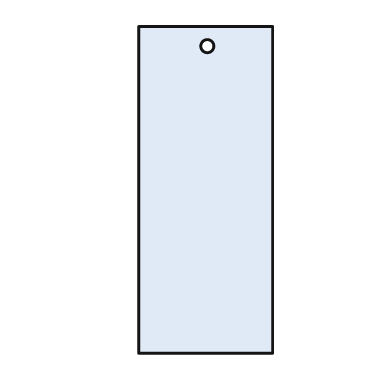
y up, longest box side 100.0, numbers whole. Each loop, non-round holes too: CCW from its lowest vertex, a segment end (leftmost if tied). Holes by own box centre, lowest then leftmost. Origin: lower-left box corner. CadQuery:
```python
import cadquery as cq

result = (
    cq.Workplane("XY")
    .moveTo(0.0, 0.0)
    .lineTo(41.0, 0.0)
    .lineTo(41.0, 100.0)
    .lineTo(0.0, 100.0)
    .close()
    .moveTo(21.0, 94.0)
    .circle(2.0)
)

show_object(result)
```